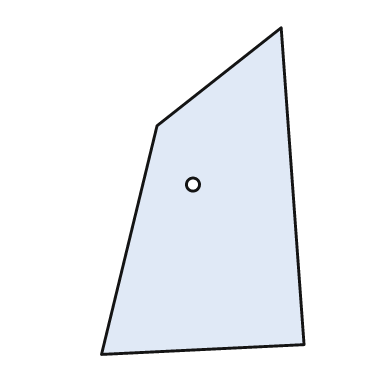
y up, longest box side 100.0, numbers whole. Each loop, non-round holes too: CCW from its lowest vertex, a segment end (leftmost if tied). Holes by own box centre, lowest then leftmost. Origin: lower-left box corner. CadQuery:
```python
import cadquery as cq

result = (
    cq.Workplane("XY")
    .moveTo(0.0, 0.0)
    .lineTo(62.0, 3.0)
    .lineTo(55.0, 100.0)
    .lineTo(17.0, 70.0)
    .close()
    .moveTo(28.0, 52.0)
    .circle(2.0)
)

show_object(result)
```